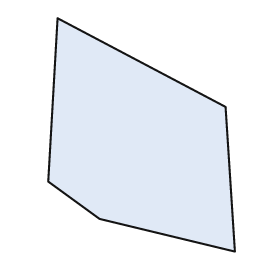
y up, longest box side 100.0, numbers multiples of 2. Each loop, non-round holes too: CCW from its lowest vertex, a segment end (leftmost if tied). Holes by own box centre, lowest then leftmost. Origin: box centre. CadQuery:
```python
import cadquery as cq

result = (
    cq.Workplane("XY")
    .moveTo(40.0, -50.0)
    .lineTo(36.0, 12.0)
    .lineTo(-36.0, 50.0)
    .lineTo(-40.0, -20.0)
    .lineTo(-18.0, -36.0)
    .close()
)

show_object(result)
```